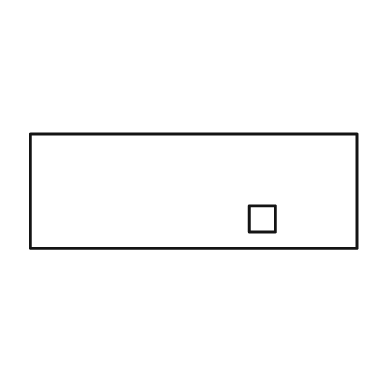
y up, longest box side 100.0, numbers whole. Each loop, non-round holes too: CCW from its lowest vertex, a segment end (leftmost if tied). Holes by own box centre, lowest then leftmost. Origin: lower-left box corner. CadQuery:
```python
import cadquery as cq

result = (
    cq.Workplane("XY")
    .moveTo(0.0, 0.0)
    .lineTo(100.0, 0.0)
    .lineTo(100.0, 35.0)
    .lineTo(0.0, 35.0)
    .close()
    .moveTo(67.0, 5.0)
    .lineTo(75.0, 5.0)
    .lineTo(75.0, 13.0)
    .lineTo(67.0, 13.0)
    .close()
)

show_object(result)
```